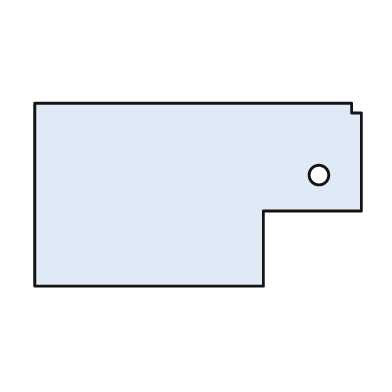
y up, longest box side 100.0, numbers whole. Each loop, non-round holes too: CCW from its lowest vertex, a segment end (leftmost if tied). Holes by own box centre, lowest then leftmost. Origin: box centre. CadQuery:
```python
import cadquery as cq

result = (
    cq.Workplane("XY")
    .moveTo(-50.0, -28.0)
    .lineTo(20.0, -28.0)
    .lineTo(20.0, -5.0)
    .lineTo(50.0, -5.0)
    .lineTo(50.0, 25.0)
    .lineTo(47.0, 25.0)
    .lineTo(47.0, 28.0)
    .lineTo(-50.0, 28.0)
    .close()
    .moveTo(37.0, 6.0)
    .circle(3.0)
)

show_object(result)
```